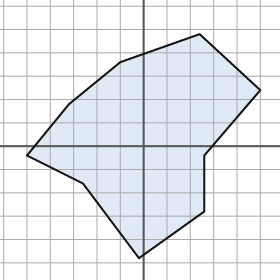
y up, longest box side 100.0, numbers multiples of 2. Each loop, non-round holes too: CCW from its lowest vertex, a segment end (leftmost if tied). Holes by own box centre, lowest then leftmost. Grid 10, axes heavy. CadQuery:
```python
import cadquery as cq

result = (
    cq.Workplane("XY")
    .moveTo(-2.0, -48.0)
    .lineTo(26.0, -28.0)
    .lineTo(26.0, -4.0)
    .lineTo(50.0, 24.0)
    .lineTo(24.0, 48.0)
    .lineTo(-10.0, 36.0)
    .lineTo(-32.0, 18.0)
    .lineTo(-50.0, -4.0)
    .lineTo(-26.0, -16.0)
    .close()
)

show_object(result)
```